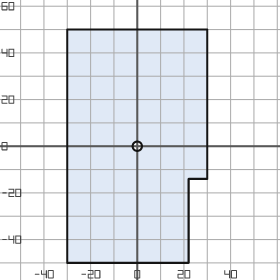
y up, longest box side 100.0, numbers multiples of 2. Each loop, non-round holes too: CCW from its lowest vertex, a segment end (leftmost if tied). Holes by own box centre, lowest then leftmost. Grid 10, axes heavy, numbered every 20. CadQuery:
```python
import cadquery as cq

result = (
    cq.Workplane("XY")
    .moveTo(-30.0, -50.0)
    .lineTo(22.0, -50.0)
    .lineTo(22.0, -14.0)
    .lineTo(30.0, -14.0)
    .lineTo(30.0, 50.0)
    .lineTo(-30.0, 50.0)
    .close()
    .moveTo(0.0, 0.0)
    .circle(2.0)
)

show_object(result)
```